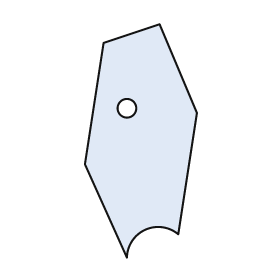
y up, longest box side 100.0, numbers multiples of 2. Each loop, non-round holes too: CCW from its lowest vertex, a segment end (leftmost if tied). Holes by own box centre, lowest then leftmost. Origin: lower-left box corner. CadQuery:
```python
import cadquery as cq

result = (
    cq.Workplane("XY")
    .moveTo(18.0, 0.0)
    .threePointArc((26.0, 12.0), (40.0, 10.0))
    .lineTo(48.0, 62.0)
    .lineTo(32.0, 100.0)
    .lineTo(8.0, 92.0)
    .lineTo(0.0, 40.0)
    .close()
    .moveTo(18.0, 64.0)
    .circle(4.0)
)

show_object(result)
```